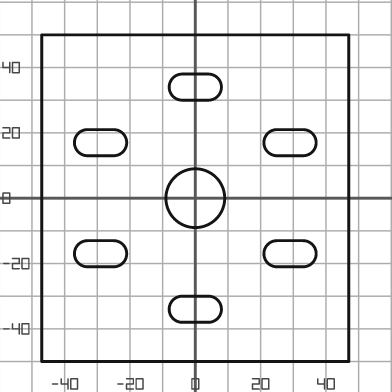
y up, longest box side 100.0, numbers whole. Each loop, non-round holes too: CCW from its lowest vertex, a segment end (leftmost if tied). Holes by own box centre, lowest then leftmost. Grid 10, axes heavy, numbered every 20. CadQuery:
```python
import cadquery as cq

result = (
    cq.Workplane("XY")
    .moveTo(-47.0, -50.0)
    .lineTo(47.0, -50.0)
    .lineTo(47.0, 50.0)
    .lineTo(-47.0, 50.0)
    .close()
    .moveTo(-4.0, -38.0)
    .lineTo(4.0, -38.0)
    .threePointArc((8.0, -34.0), (4.0, -30.0))
    .lineTo(-4.0, -30.0)
    .threePointArc((-8.0, -34.0), (-4.0, -38.0))
    .close()
    .moveTo(-33.0, -21.0)
    .lineTo(-25.0, -21.0)
    .threePointArc((-21.0, -17.0), (-25.0, -13.0))
    .lineTo(-33.0, -13.0)
    .threePointArc((-37.0, -17.0), (-33.0, -21.0))
    .close()
    .moveTo(25.0, -21.0)
    .lineTo(33.0, -21.0)
    .threePointArc((37.0, -17.0), (33.0, -13.0))
    .lineTo(25.0, -13.0)
    .threePointArc((21.0, -17.0), (25.0, -21.0))
    .close()
    .moveTo(0.0, 0.0)
    .circle(9.0)
    .moveTo(-33.0, 13.0)
    .lineTo(-25.0, 13.0)
    .threePointArc((-21.0, 17.0), (-25.0, 21.0))
    .lineTo(-33.0, 21.0)
    .threePointArc((-37.0, 17.0), (-33.0, 13.0))
    .close()
    .moveTo(25.0, 13.0)
    .lineTo(33.0, 13.0)
    .threePointArc((37.0, 17.0), (33.0, 21.0))
    .lineTo(25.0, 21.0)
    .threePointArc((21.0, 17.0), (25.0, 13.0))
    .close()
    .moveTo(-4.0, 30.0)
    .lineTo(4.0, 30.0)
    .threePointArc((8.0, 34.0), (4.0, 38.0))
    .lineTo(-4.0, 38.0)
    .threePointArc((-8.0, 34.0), (-4.0, 30.0))
    .close()
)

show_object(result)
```